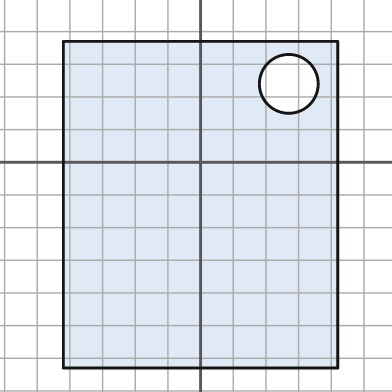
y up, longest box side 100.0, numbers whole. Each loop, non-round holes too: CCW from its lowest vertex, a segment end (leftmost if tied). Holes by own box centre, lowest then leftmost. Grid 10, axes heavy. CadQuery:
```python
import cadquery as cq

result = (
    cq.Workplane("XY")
    .moveTo(-42.0, -63.0)
    .lineTo(42.0, -63.0)
    .lineTo(42.0, 37.0)
    .lineTo(-42.0, 37.0)
    .close()
    .moveTo(27.0, 24.0)
    .circle(9.0)
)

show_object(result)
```